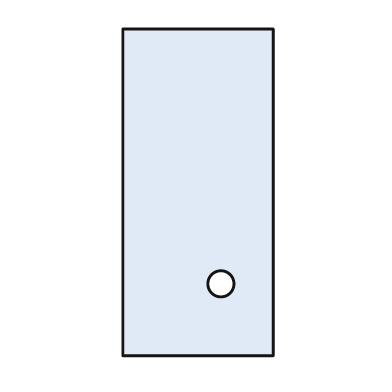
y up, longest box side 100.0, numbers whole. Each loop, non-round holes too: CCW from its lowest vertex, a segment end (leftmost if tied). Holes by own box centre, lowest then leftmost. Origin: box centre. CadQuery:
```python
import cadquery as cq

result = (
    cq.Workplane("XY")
    .moveTo(-23.0, -50.0)
    .lineTo(23.0, -50.0)
    .lineTo(23.0, 50.0)
    .lineTo(-23.0, 50.0)
    .close()
    .moveTo(7.0, -28.0)
    .circle(4.0)
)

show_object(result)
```